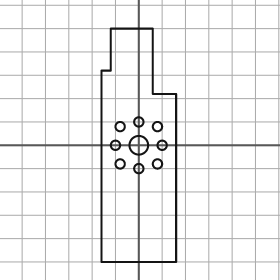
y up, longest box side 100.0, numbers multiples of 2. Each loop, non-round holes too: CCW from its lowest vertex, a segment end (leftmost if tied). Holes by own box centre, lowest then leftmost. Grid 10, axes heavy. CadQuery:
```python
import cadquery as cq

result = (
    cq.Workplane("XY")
    .moveTo(-16.0, -50.0)
    .lineTo(16.0, -50.0)
    .lineTo(16.0, 22.0)
    .lineTo(6.0, 22.0)
    .lineTo(6.0, 50.0)
    .lineTo(-12.0, 50.0)
    .lineTo(-12.0, 32.0)
    .lineTo(-16.0, 32.0)
    .close()
    .moveTo(0.0, -10.0)
    .circle(2.0)
    .moveTo(-8.0, -8.0)
    .circle(2.0)
    .moveTo(8.0, -8.0)
    .circle(2.0)
    .moveTo(-10.0, 0.0)
    .circle(2.0)
    .moveTo(0.0, 0.0)
    .circle(4.0)
    .moveTo(10.0, 0.0)
    .circle(2.0)
    .moveTo(-8.0, 8.0)
    .circle(2.0)
    .moveTo(8.0, 8.0)
    .circle(2.0)
    .moveTo(0.0, 10.0)
    .circle(2.0)
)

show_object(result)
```